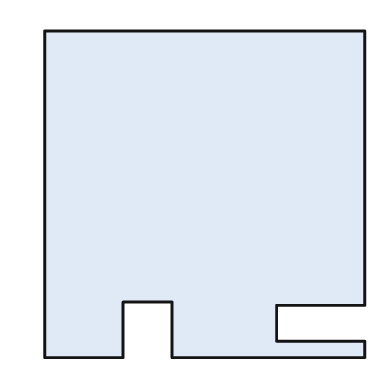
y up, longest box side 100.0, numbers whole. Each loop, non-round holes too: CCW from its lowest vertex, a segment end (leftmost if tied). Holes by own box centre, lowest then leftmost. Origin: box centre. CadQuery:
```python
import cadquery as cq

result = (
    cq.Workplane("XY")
    .moveTo(-49.0, -50.0)
    .lineTo(-25.0, -50.0)
    .lineTo(-25.0, -33.0)
    .lineTo(-10.0, -33.0)
    .lineTo(-10.0, -50.0)
    .lineTo(49.0, -50.0)
    .lineTo(49.0, -45.0)
    .lineTo(22.0, -45.0)
    .lineTo(22.0, -34.0)
    .lineTo(49.0, -34.0)
    .lineTo(49.0, 50.0)
    .lineTo(-49.0, 50.0)
    .close()
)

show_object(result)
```